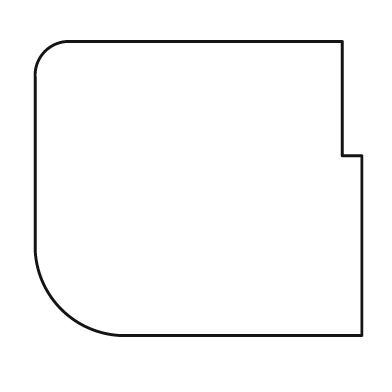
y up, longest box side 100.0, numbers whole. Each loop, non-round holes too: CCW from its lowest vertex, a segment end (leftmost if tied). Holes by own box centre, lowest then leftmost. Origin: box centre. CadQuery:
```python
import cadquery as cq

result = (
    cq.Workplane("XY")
    .moveTo(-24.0, -45.0)
    .lineTo(50.0, -45.0)
    .lineTo(50.0, 10.0)
    .lineTo(44.0, 10.0)
    .lineTo(44.0, 45.0)
    .lineTo(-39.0, 45.0)
    .threePointArc((-47.0, 42.0), (-50.0, 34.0))
    .lineTo(-50.0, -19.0)
    .threePointArc((-42.0, -37.0), (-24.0, -45.0))
    .close()
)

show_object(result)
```